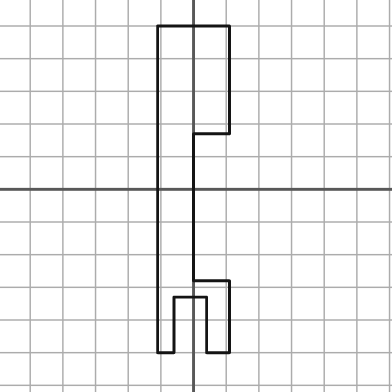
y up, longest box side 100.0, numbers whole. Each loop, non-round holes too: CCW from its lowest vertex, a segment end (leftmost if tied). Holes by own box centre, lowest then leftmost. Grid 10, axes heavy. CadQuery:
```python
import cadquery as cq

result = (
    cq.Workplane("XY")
    .moveTo(-11.0, -50.0)
    .lineTo(-6.0, -50.0)
    .lineTo(-6.0, -33.0)
    .lineTo(4.0, -33.0)
    .lineTo(4.0, -50.0)
    .lineTo(11.0, -50.0)
    .lineTo(11.0, -28.0)
    .lineTo(0.0, -28.0)
    .lineTo(0.0, 17.0)
    .lineTo(11.0, 17.0)
    .lineTo(11.0, 50.0)
    .lineTo(-11.0, 50.0)
    .close()
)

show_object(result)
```